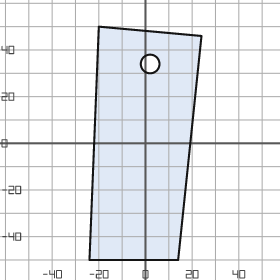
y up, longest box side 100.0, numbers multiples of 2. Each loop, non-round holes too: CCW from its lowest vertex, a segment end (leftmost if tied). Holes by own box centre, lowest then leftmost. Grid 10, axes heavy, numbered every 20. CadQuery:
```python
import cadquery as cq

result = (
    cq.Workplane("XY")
    .moveTo(-24.0, -50.0)
    .lineTo(14.0, -50.0)
    .lineTo(24.0, 46.0)
    .lineTo(-20.0, 50.0)
    .close()
    .moveTo(2.0, 34.0)
    .circle(4.0)
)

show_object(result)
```